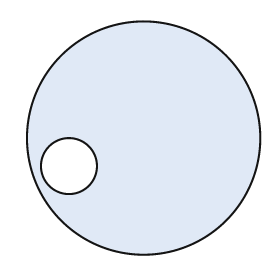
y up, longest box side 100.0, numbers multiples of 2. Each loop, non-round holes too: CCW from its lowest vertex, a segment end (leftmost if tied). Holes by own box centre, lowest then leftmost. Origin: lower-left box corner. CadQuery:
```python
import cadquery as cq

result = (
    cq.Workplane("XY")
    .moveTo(50.0, 50.0)
    .circle(50.0)
    .moveTo(18.0, 38.0)
    .circle(12.0)
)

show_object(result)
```